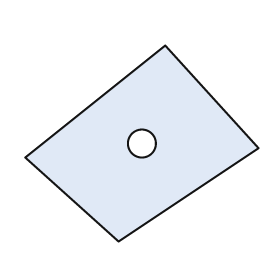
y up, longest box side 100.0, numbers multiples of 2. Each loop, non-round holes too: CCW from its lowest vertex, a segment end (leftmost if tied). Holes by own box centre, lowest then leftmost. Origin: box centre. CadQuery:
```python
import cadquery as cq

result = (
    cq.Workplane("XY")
    .moveTo(-10.0, -42.0)
    .lineTo(50.0, -2.0)
    .lineTo(10.0, 42.0)
    .lineTo(-50.0, -6.0)
    .close()
    .moveTo(0.0, 0.0)
    .circle(6.0)
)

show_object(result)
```